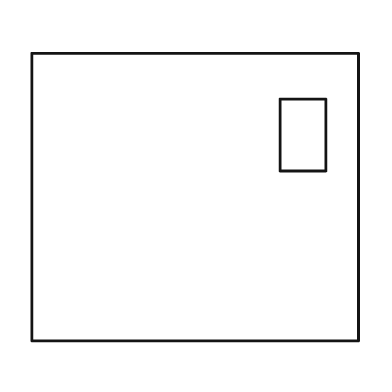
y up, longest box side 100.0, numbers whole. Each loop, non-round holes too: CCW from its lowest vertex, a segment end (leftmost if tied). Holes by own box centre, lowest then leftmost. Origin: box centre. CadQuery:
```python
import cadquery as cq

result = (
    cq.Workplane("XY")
    .moveTo(-50.0, -44.0)
    .lineTo(50.0, -44.0)
    .lineTo(50.0, 44.0)
    .lineTo(-50.0, 44.0)
    .close()
    .moveTo(26.0, 8.0)
    .lineTo(40.0, 8.0)
    .lineTo(40.0, 30.0)
    .lineTo(26.0, 30.0)
    .close()
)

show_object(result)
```